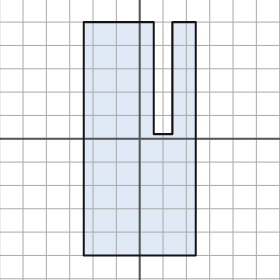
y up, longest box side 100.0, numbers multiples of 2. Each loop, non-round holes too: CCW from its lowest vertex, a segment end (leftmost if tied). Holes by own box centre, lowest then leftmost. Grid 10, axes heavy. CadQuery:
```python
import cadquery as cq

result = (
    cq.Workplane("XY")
    .moveTo(-24.0, -50.0)
    .lineTo(24.0, -50.0)
    .lineTo(24.0, 50.0)
    .lineTo(14.0, 50.0)
    .lineTo(14.0, 2.0)
    .lineTo(6.0, 2.0)
    .lineTo(6.0, 50.0)
    .lineTo(-24.0, 50.0)
    .close()
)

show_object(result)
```